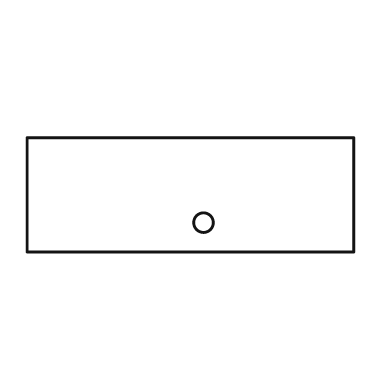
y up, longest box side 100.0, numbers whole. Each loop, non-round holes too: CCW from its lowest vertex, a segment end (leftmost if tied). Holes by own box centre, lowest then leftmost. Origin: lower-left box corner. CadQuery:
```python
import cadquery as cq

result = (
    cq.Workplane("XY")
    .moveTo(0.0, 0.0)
    .lineTo(100.0, 0.0)
    .lineTo(100.0, 35.0)
    .lineTo(0.0, 35.0)
    .close()
    .moveTo(54.0, 9.0)
    .circle(3.0)
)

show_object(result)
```